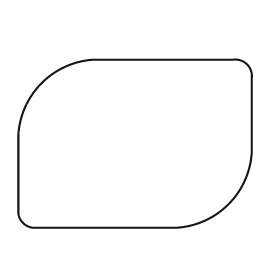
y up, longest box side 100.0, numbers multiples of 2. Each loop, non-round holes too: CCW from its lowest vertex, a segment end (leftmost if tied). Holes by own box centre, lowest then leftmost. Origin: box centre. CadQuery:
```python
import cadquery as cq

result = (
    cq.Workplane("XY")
    .moveTo(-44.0, -36.0)
    .lineTo(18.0, -36.0)
    .threePointArc((40.0, -26.0), (50.0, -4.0))
    .lineTo(50.0, 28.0)
    .threePointArc((48.0, 34.0), (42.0, 36.0))
    .lineTo(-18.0, 36.0)
    .threePointArc((-40.0, 26.0), (-50.0, 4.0))
    .lineTo(-50.0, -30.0)
    .threePointArc((-48.0, -34.0), (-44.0, -36.0))
    .close()
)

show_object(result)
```